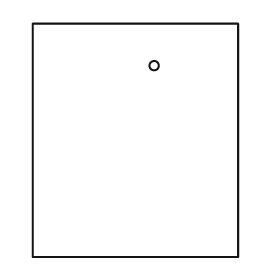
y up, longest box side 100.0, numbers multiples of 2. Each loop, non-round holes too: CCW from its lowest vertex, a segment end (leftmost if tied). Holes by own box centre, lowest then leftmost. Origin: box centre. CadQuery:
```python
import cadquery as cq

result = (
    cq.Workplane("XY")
    .moveTo(-44.0, -50.0)
    .lineTo(44.0, -50.0)
    .lineTo(44.0, 50.0)
    .lineTo(-44.0, 50.0)
    .close()
    .moveTo(8.0, 32.0)
    .circle(2.0)
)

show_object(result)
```